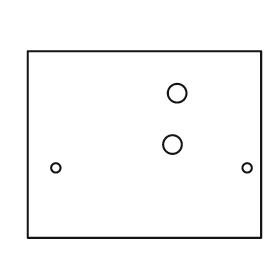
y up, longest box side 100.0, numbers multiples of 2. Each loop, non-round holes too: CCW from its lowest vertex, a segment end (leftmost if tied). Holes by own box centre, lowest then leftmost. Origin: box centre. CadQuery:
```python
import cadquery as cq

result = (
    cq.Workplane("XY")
    .moveTo(-50.0, -40.0)
    .lineTo(50.0, -40.0)
    .lineTo(50.0, 40.0)
    .lineTo(-50.0, 40.0)
    .close()
    .moveTo(-38.0, -10.0)
    .circle(2.0)
    .moveTo(44.0, -10.0)
    .circle(2.0)
    .moveTo(12.0, 0.0)
    .circle(4.0)
    .moveTo(14.0, 22.0)
    .circle(4.0)
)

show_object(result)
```